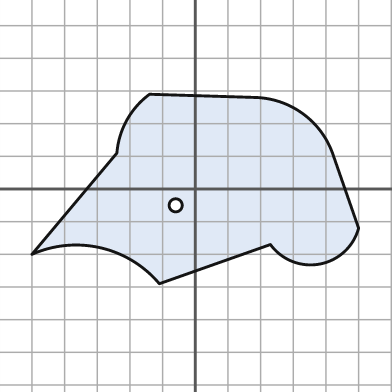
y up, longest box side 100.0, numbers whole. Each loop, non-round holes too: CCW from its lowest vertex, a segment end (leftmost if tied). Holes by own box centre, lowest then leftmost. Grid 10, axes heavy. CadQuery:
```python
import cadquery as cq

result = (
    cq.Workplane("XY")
    .moveTo(-11.0, -29.0)
    .lineTo(23.0, -17.0)
    .threePointArc((38.0, -23.0), (50.0, -12.0))
    .lineTo(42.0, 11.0)
    .threePointArc((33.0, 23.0), (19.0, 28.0))
    .lineTo(-14.0, 29.0)
    .threePointArc((-21.0, 21.0), (-24.0, 11.0))
    .lineTo(-50.0, -20.0)
    .threePointArc((-29.0, -18.0), (-11.0, -29.0))
    .close()
    .moveTo(-6.0, -5.0)
    .circle(2.0)
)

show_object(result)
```